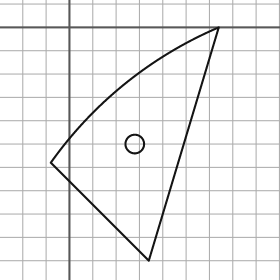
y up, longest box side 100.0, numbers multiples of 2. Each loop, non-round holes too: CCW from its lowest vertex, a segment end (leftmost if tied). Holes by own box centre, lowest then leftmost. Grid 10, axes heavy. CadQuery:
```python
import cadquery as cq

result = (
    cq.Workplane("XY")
    .moveTo(34.0, -100.0)
    .lineTo(64.0, 0.0)
    .threePointArc((24.0, -24.0), (-8.0, -58.0))
    .close()
    .moveTo(28.0, -50.0)
    .circle(4.0)
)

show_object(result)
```